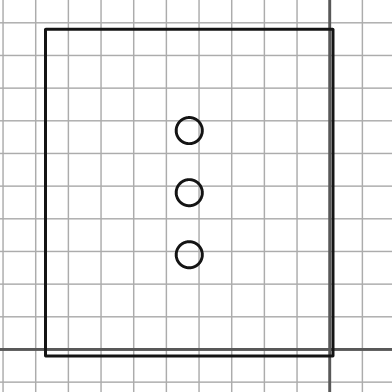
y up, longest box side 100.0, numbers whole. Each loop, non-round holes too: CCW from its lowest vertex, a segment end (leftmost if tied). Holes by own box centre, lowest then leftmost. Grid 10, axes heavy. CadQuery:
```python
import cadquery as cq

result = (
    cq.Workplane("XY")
    .moveTo(-87.0, -2.0)
    .lineTo(1.0, -2.0)
    .lineTo(1.0, 98.0)
    .lineTo(-87.0, 98.0)
    .close()
    .moveTo(-43.0, 29.0)
    .circle(4.0)
    .moveTo(-43.0, 48.0)
    .circle(4.0)
    .moveTo(-43.0, 67.0)
    .circle(4.0)
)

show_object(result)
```